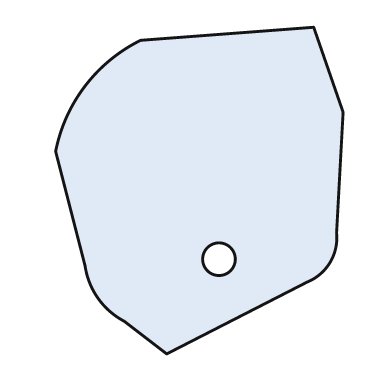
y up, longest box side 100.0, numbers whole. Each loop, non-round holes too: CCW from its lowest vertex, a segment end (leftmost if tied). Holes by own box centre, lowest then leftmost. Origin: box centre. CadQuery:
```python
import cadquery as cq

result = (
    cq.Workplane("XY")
    .moveTo(-10.0, -50.0)
    .lineTo(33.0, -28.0)
    .threePointArc((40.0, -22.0), (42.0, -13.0))
    .lineTo(44.0, 24.0)
    .lineTo(35.0, 50.0)
    .lineTo(-18.0, 46.0)
    .threePointArc((-35.0, 32.0), (-44.0, 12.0))
    .lineTo(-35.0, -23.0)
    .threePointArc((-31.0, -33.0), (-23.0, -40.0))
    .close()
    .moveTo(6.0, -21.0)
    .circle(5.0)
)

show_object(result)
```